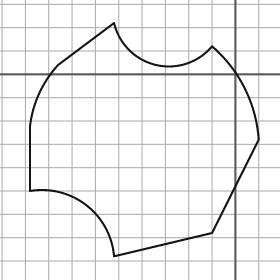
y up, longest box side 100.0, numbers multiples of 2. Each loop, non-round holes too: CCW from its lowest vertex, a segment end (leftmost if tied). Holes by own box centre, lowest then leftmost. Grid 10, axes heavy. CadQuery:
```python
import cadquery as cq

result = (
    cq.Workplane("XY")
    .moveTo(-52.0, -78.0)
    .lineTo(-10.0, -68.0)
    .lineTo(10.0, -28.0)
    .threePointArc((4.0, -6.0), (-10.0, 12.0))
    .threePointArc((-34.0, 4.0), (-52.0, 22.0))
    .lineTo(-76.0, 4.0)
    .threePointArc((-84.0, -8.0), (-88.0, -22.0))
    .lineTo(-88.0, -50.0)
    .threePointArc((-64.0, -56.0), (-52.0, -78.0))
    .close()
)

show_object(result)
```